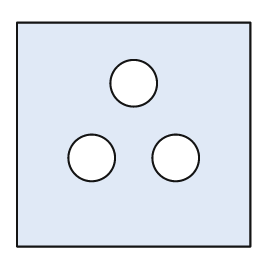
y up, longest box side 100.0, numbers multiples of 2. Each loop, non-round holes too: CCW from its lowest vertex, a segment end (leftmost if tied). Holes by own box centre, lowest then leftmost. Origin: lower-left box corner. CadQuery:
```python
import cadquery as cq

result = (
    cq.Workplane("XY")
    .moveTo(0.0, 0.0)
    .lineTo(100.0, 0.0)
    .lineTo(100.0, 96.0)
    .lineTo(0.0, 96.0)
    .close()
    .moveTo(32.0, 38.0)
    .circle(10.0)
    .moveTo(68.0, 38.0)
    .circle(10.0)
    .moveTo(50.0, 70.0)
    .circle(10.0)
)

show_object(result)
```